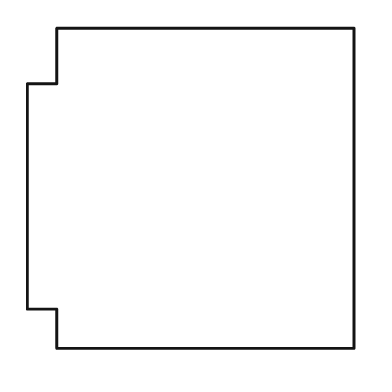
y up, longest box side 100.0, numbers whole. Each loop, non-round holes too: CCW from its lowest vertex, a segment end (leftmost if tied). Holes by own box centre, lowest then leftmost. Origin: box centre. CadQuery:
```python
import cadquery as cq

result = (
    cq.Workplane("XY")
    .moveTo(-41.0, -49.0)
    .lineTo(50.0, -49.0)
    .lineTo(50.0, 49.0)
    .lineTo(-41.0, 49.0)
    .lineTo(-41.0, 32.0)
    .lineTo(-50.0, 32.0)
    .lineTo(-50.0, -37.0)
    .lineTo(-41.0, -37.0)
    .close()
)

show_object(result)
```